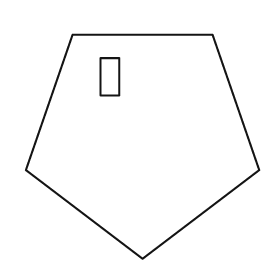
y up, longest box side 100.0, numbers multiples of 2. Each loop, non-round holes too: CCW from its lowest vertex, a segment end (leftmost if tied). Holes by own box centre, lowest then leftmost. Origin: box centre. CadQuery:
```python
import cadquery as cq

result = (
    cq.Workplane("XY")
    .moveTo(0.0, -48.0)
    .lineTo(50.0, -10.0)
    .lineTo(30.0, 48.0)
    .lineTo(-30.0, 48.0)
    .lineTo(-50.0, -10.0)
    .close()
    .moveTo(-18.0, 22.0)
    .lineTo(-10.0, 22.0)
    .lineTo(-10.0, 38.0)
    .lineTo(-18.0, 38.0)
    .close()
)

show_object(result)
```